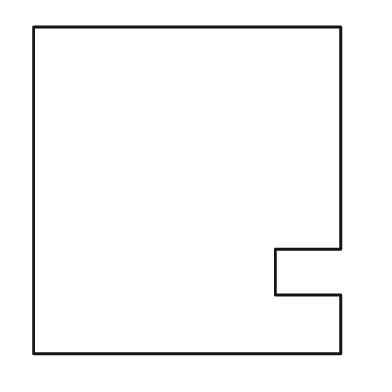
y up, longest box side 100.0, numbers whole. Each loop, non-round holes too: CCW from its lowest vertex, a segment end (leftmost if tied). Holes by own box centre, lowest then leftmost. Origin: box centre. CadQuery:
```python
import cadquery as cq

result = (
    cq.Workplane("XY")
    .moveTo(-47.0, -50.0)
    .lineTo(47.0, -50.0)
    .lineTo(47.0, -32.0)
    .lineTo(27.0, -32.0)
    .lineTo(27.0, -18.0)
    .lineTo(47.0, -18.0)
    .lineTo(47.0, 50.0)
    .lineTo(-47.0, 50.0)
    .close()
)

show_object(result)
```